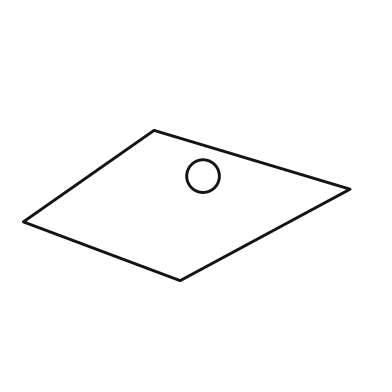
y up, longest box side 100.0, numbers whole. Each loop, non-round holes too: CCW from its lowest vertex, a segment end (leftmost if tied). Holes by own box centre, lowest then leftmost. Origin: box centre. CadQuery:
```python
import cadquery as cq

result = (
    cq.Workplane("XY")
    .moveTo(-2.0, -23.0)
    .lineTo(50.0, 5.0)
    .lineTo(-10.0, 23.0)
    .lineTo(-50.0, -5.0)
    .close()
    .moveTo(5.0, 9.0)
    .circle(5.0)
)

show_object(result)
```